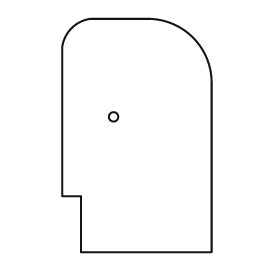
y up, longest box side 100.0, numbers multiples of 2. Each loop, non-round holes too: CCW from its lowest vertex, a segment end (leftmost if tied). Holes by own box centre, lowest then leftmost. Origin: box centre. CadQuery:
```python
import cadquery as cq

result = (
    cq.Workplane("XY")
    .moveTo(-24.0, -50.0)
    .lineTo(32.0, -50.0)
    .lineTo(32.0, 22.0)
    .threePointArc((24.0, 42.0), (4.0, 50.0))
    .lineTo(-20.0, 50.0)
    .threePointArc((-28.0, 46.0), (-32.0, 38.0))
    .lineTo(-32.0, -26.0)
    .lineTo(-24.0, -26.0)
    .close()
    .moveTo(-10.0, 8.0)
    .circle(2.0)
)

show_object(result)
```